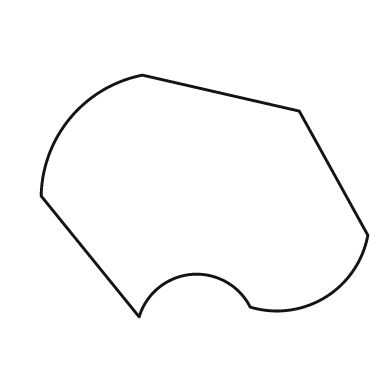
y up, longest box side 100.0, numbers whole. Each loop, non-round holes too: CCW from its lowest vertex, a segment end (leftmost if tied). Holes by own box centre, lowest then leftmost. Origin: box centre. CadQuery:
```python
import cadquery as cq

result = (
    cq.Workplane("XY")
    .moveTo(-20.0, -37.0)
    .threePointArc((-4.0, -24.0), (14.0, -34.0))
    .threePointArc((37.0, -31.0), (50.0, -12.0))
    .lineTo(29.0, 26.0)
    .lineTo(-19.0, 37.0)
    .threePointArc((-41.0, 24.0), (-50.0, 0.0))
    .close()
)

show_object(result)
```